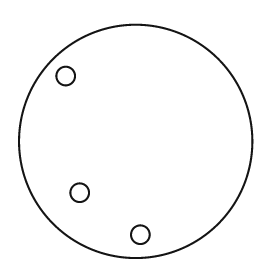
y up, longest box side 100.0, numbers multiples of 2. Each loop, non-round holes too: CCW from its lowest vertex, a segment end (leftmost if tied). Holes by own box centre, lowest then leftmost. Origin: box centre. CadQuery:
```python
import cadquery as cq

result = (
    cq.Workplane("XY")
    .moveTo(0.0, 0.0)
    .circle(50.0)
    .moveTo(2.0, -40.0)
    .circle(4.0)
    .moveTo(-24.0, -22.0)
    .circle(4.0)
    .moveTo(-30.0, 28.0)
    .circle(4.0)
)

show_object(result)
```